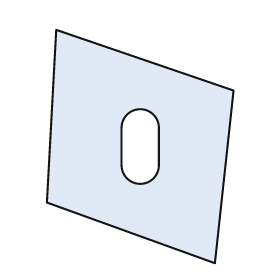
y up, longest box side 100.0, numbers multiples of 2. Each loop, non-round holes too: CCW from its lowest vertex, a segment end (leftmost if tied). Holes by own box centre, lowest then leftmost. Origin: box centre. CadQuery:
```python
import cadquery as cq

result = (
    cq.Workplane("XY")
    .moveTo(32.0, -50.0)
    .lineTo(40.0, 24.0)
    .lineTo(-36.0, 50.0)
    .lineTo(-40.0, -24.0)
    .close()
    .moveTo(-8.0, -8.0)
    .threePointArc((0.0, -16.0), (8.0, -8.0))
    .lineTo(8.0, 8.0)
    .threePointArc((0.0, 16.0), (-8.0, 8.0))
    .close()
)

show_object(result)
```